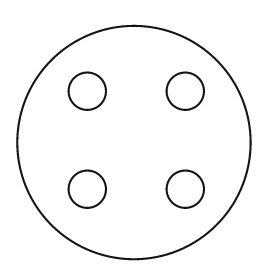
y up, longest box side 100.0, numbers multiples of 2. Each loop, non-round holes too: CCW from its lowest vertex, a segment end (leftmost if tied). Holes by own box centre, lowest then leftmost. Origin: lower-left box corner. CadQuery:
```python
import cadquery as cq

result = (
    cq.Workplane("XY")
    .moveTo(50.0, 50.0)
    .circle(50.0)
    .moveTo(30.0, 30.0)
    .circle(8.0)
    .moveTo(72.0, 30.0)
    .circle(8.0)
    .moveTo(30.0, 72.0)
    .circle(8.0)
    .moveTo(72.0, 72.0)
    .circle(8.0)
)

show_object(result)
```